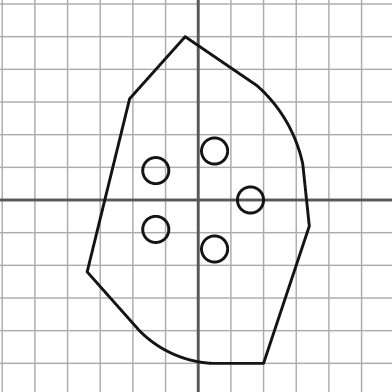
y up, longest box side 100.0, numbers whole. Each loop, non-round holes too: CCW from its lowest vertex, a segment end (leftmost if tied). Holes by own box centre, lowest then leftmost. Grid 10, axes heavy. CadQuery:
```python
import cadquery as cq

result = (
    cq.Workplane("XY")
    .moveTo(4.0, -50.0)
    .lineTo(20.0, -50.0)
    .lineTo(34.0, -8.0)
    .lineTo(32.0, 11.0)
    .threePointArc((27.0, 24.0), (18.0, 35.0))
    .lineTo(-4.0, 50.0)
    .lineTo(-21.0, 31.0)
    .lineTo(-34.0, -22.0)
    .lineTo(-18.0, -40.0)
    .threePointArc((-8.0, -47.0), (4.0, -50.0))
    .close()
    .moveTo(5.0, -15.0)
    .circle(4.0)
    .moveTo(-13.0, -9.0)
    .circle(4.0)
    .moveTo(16.0, 0.0)
    .circle(4.0)
    .moveTo(-13.0, 9.0)
    .circle(4.0)
    .moveTo(5.0, 15.0)
    .circle(4.0)
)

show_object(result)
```